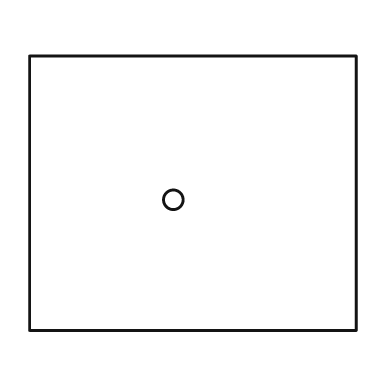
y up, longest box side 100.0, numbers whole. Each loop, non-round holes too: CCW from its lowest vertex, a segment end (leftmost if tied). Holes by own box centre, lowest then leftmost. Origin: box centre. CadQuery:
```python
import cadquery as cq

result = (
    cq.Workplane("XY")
    .moveTo(-50.0, -42.0)
    .lineTo(50.0, -42.0)
    .lineTo(50.0, 42.0)
    .lineTo(-50.0, 42.0)
    .close()
    .moveTo(-6.0, -2.0)
    .circle(3.0)
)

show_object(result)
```